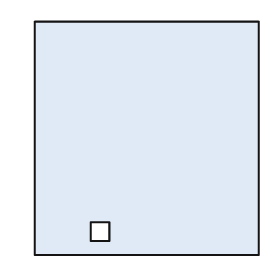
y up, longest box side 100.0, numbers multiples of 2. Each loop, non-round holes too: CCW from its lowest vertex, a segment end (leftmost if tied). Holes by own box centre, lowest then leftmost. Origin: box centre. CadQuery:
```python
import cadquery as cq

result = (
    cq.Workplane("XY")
    .moveTo(-48.0, -50.0)
    .lineTo(48.0, -50.0)
    .lineTo(48.0, 50.0)
    .lineTo(-48.0, 50.0)
    .close()
    .moveTo(-24.0, -44.0)
    .lineTo(-16.0, -44.0)
    .lineTo(-16.0, -36.0)
    .lineTo(-24.0, -36.0)
    .close()
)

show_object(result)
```